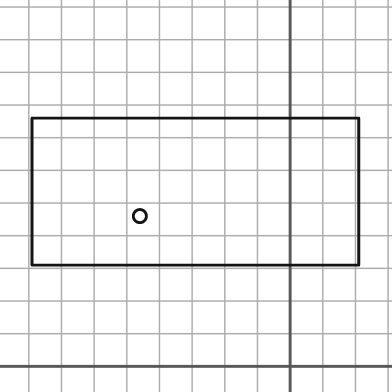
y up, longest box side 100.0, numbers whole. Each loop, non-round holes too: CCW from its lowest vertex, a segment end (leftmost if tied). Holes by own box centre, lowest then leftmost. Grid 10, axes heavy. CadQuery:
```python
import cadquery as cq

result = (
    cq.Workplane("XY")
    .moveTo(-79.0, 31.0)
    .lineTo(21.0, 31.0)
    .lineTo(21.0, 76.0)
    .lineTo(-79.0, 76.0)
    .close()
    .moveTo(-46.0, 46.0)
    .circle(2.0)
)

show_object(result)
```